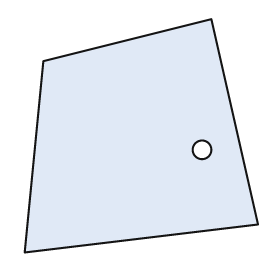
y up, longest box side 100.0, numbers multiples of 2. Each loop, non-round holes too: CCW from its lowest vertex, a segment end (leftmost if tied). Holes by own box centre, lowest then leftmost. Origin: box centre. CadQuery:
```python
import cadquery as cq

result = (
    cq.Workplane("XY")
    .moveTo(-50.0, -50.0)
    .lineTo(50.0, -38.0)
    .lineTo(30.0, 50.0)
    .lineTo(-42.0, 32.0)
    .close()
    .moveTo(26.0, -6.0)
    .circle(4.0)
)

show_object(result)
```